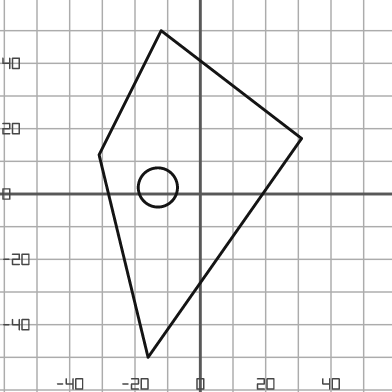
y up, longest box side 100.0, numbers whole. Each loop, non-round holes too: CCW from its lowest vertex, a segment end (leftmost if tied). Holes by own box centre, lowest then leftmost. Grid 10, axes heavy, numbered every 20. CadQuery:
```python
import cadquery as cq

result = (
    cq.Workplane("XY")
    .moveTo(-16.0, -50.0)
    .lineTo(31.0, 17.0)
    .lineTo(-12.0, 50.0)
    .lineTo(-31.0, 12.0)
    .close()
    .moveTo(-13.0, 2.0)
    .circle(6.0)
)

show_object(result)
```